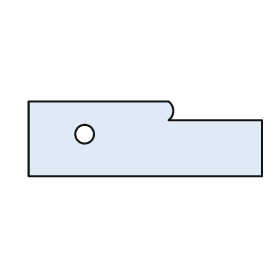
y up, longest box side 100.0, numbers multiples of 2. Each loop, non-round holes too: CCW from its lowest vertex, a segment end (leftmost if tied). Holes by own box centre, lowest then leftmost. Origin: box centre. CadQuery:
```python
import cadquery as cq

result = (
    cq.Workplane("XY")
    .moveTo(-50.0, -16.0)
    .lineTo(50.0, -16.0)
    .lineTo(50.0, 8.0)
    .lineTo(10.0, 8.0)
    .threePointArc((12.0, 12.0), (10.0, 16.0))
    .lineTo(-50.0, 16.0)
    .close()
    .moveTo(-26.0, 2.0)
    .circle(4.0)
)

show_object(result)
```